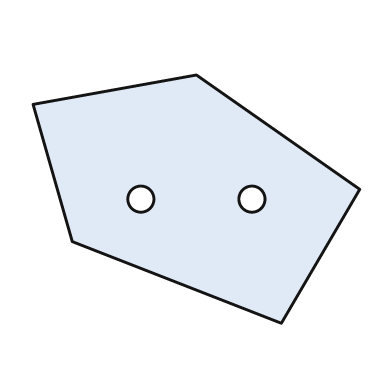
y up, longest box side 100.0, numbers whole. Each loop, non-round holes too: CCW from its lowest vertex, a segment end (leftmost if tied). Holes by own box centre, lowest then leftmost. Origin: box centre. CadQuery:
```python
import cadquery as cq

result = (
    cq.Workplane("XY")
    .moveTo(26.0, -38.0)
    .lineTo(50.0, 3.0)
    .lineTo(0.0, 38.0)
    .lineTo(-50.0, 29.0)
    .lineTo(-38.0, -13.0)
    .close()
    .moveTo(-17.0, 0.0)
    .circle(4.0)
    .moveTo(17.0, 0.0)
    .circle(4.0)
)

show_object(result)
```